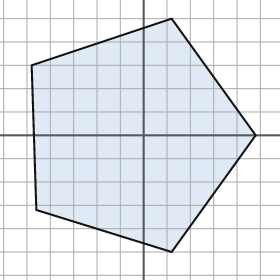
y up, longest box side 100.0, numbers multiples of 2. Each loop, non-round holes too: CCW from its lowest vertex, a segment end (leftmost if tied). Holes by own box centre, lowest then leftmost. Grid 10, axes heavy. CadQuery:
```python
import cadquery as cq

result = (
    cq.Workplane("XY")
    .moveTo(12.0, -50.0)
    .lineTo(48.0, 0.0)
    .lineTo(12.0, 50.0)
    .lineTo(-48.0, 30.0)
    .lineTo(-46.0, -32.0)
    .close()
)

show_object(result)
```